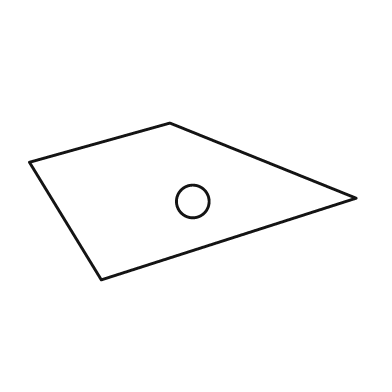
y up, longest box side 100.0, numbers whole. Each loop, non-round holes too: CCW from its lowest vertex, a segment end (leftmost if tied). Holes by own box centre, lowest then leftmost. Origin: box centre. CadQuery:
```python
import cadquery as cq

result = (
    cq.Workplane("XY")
    .moveTo(-28.0, -24.0)
    .lineTo(50.0, 1.0)
    .lineTo(-7.0, 24.0)
    .lineTo(-50.0, 12.0)
    .close()
    .moveTo(0.0, 0.0)
    .circle(5.0)
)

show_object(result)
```